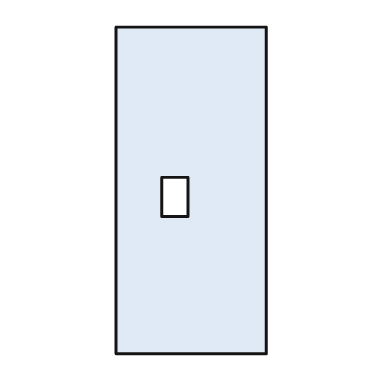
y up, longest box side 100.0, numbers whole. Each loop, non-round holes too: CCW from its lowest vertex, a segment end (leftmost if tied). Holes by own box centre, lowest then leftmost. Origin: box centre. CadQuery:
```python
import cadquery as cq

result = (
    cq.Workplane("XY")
    .moveTo(-23.0, -50.0)
    .lineTo(23.0, -50.0)
    .lineTo(23.0, 50.0)
    .lineTo(-23.0, 50.0)
    .close()
    .moveTo(-9.0, -8.0)
    .lineTo(-1.0, -8.0)
    .lineTo(-1.0, 4.0)
    .lineTo(-9.0, 4.0)
    .close()
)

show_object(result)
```